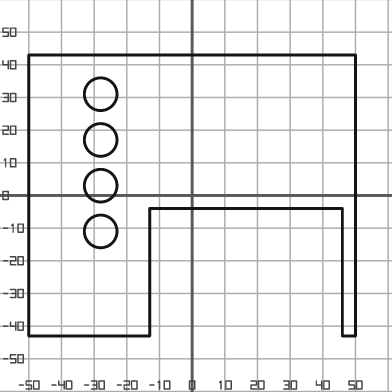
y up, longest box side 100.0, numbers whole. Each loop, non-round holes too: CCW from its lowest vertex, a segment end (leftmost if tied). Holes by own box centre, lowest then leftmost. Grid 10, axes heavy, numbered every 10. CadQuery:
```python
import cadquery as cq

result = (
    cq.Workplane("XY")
    .moveTo(-50.0, -43.0)
    .lineTo(-13.0, -43.0)
    .lineTo(-13.0, -4.0)
    .lineTo(46.0, -4.0)
    .lineTo(46.0, -43.0)
    .lineTo(50.0, -43.0)
    .lineTo(50.0, 43.0)
    .lineTo(-50.0, 43.0)
    .close()
    .moveTo(-28.0, -11.0)
    .circle(5.0)
    .moveTo(-28.0, 3.0)
    .circle(5.0)
    .moveTo(-28.0, 17.0)
    .circle(5.0)
    .moveTo(-28.0, 31.0)
    .circle(5.0)
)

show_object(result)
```